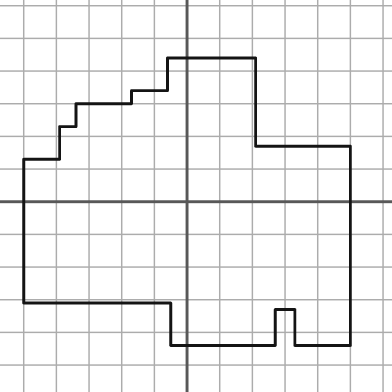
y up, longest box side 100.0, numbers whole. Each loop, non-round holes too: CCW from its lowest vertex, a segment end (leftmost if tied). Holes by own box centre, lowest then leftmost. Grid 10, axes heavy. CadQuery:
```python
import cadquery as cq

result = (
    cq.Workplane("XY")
    .moveTo(-5.0, -44.0)
    .lineTo(27.0, -44.0)
    .lineTo(27.0, -33.0)
    .lineTo(33.0, -33.0)
    .lineTo(33.0, -44.0)
    .lineTo(50.0, -44.0)
    .lineTo(50.0, 17.0)
    .lineTo(21.0, 17.0)
    .lineTo(21.0, 44.0)
    .lineTo(-6.0, 44.0)
    .lineTo(-6.0, 34.0)
    .lineTo(-17.0, 34.0)
    .lineTo(-17.0, 30.0)
    .lineTo(-34.0, 30.0)
    .lineTo(-34.0, 23.0)
    .lineTo(-39.0, 23.0)
    .lineTo(-39.0, 13.0)
    .lineTo(-50.0, 13.0)
    .lineTo(-50.0, -31.0)
    .lineTo(-5.0, -31.0)
    .close()
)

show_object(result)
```